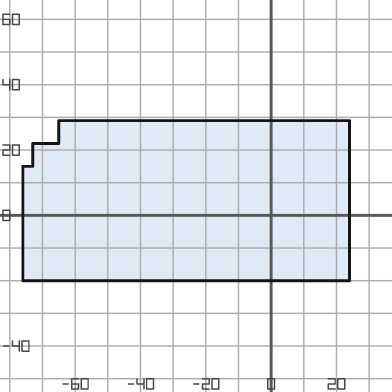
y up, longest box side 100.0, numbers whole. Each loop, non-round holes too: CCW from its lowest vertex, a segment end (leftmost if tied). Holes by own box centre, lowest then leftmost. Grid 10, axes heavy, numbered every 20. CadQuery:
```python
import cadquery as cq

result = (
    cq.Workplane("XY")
    .moveTo(-76.0, -20.0)
    .lineTo(24.0, -20.0)
    .lineTo(24.0, 29.0)
    .lineTo(-65.0, 29.0)
    .lineTo(-65.0, 22.0)
    .lineTo(-73.0, 22.0)
    .lineTo(-73.0, 15.0)
    .lineTo(-76.0, 15.0)
    .close()
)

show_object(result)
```